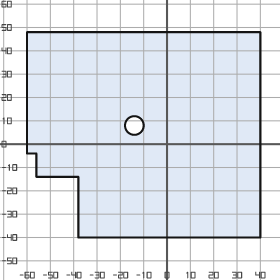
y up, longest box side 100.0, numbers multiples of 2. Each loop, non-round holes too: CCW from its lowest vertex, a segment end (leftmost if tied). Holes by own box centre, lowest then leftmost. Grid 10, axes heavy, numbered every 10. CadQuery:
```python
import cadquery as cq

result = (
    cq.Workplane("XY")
    .moveTo(-38.0, -40.0)
    .lineTo(40.0, -40.0)
    .lineTo(40.0, 48.0)
    .lineTo(-60.0, 48.0)
    .lineTo(-60.0, -4.0)
    .lineTo(-56.0, -4.0)
    .lineTo(-56.0, -14.0)
    .lineTo(-38.0, -14.0)
    .close()
    .moveTo(-14.0, 8.0)
    .circle(4.0)
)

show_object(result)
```